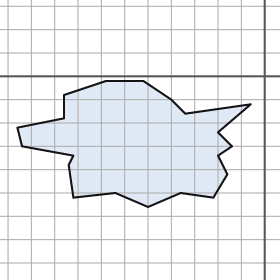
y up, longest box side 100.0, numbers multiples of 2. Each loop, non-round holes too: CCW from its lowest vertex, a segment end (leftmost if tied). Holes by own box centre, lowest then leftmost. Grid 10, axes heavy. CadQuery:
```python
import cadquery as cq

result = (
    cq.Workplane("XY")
    .moveTo(-50.0, -56.0)
    .lineTo(-36.0, -50.0)
    .lineTo(-22.0, -52.0)
    .lineTo(-16.0, -42.0)
    .lineTo(-20.0, -34.0)
    .lineTo(-14.0, -30.0)
    .lineTo(-20.0, -24.0)
    .lineTo(-6.0, -12.0)
    .lineTo(-34.0, -16.0)
    .lineTo(-40.0, -10.0)
    .lineTo(-52.0, -2.0)
    .lineTo(-68.0, -2.0)
    .lineTo(-86.0, -8.0)
    .lineTo(-86.0, -18.0)
    .lineTo(-106.0, -22.0)
    .lineTo(-104.0, -30.0)
    .lineTo(-82.0, -34.0)
    .lineTo(-84.0, -38.0)
    .lineTo(-82.0, -52.0)
    .lineTo(-64.0, -50.0)
    .close()
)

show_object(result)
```